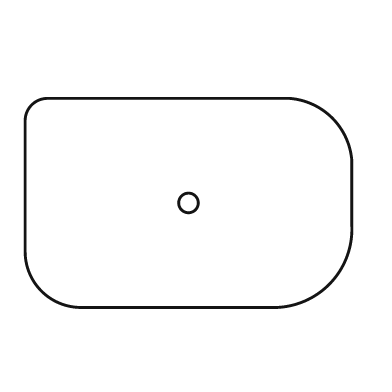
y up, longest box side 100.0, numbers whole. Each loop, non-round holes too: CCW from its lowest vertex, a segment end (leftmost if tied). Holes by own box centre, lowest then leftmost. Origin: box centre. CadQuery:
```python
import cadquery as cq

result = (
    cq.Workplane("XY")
    .moveTo(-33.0, -32.0)
    .lineTo(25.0, -32.0)
    .threePointArc((43.0, -25.0), (50.0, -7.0))
    .lineTo(50.0, 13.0)
    .threePointArc((44.0, 26.0), (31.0, 32.0))
    .lineTo(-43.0, 32.0)
    .threePointArc((-48.0, 30.0), (-50.0, 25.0))
    .lineTo(-50.0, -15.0)
    .threePointArc((-45.0, -27.0), (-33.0, -32.0))
    .close()
    .moveTo(0.0, 0.0)
    .circle(3.0)
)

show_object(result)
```